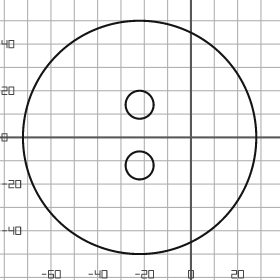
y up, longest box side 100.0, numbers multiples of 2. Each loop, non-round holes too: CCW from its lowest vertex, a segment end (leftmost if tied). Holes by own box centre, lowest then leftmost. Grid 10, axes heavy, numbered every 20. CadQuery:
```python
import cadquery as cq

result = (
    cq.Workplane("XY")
    .moveTo(-22.0, 0.0)
    .circle(50.0)
    .moveTo(-22.0, -12.0)
    .circle(6.0)
    .moveTo(-22.0, 14.0)
    .circle(6.0)
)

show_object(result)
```